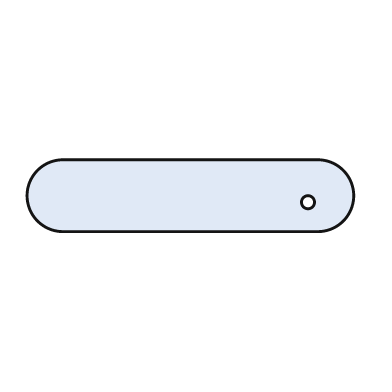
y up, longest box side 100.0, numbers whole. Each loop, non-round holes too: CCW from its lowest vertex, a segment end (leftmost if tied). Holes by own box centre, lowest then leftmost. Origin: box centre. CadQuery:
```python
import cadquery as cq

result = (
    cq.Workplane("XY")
    .moveTo(-39.0, -11.0)
    .lineTo(39.0, -11.0)
    .threePointArc((50.0, 0.0), (39.0, 11.0))
    .lineTo(-39.0, 11.0)
    .threePointArc((-50.0, 0.0), (-39.0, -11.0))
    .close()
    .moveTo(36.0, -2.0)
    .circle(2.0)
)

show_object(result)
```